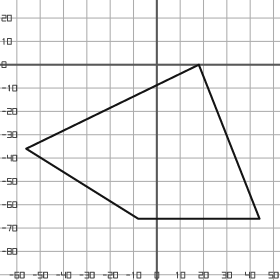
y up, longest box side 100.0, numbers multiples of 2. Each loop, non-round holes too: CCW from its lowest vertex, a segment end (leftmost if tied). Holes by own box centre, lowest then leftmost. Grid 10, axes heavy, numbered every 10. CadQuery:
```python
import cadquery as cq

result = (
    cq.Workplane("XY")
    .moveTo(-8.0, -66.0)
    .lineTo(44.0, -66.0)
    .lineTo(18.0, 0.0)
    .lineTo(-56.0, -36.0)
    .close()
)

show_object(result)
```